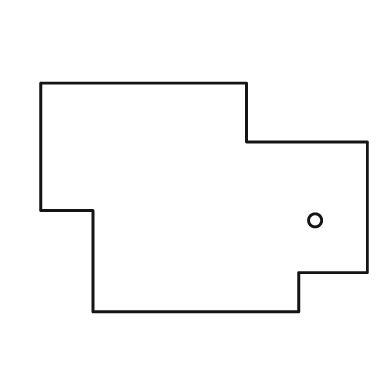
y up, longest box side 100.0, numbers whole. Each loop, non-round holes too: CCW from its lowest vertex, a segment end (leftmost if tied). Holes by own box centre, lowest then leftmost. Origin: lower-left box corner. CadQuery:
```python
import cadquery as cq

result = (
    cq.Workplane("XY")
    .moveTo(16.0, 0.0)
    .lineTo(79.0, 0.0)
    .lineTo(79.0, 12.0)
    .lineTo(100.0, 12.0)
    .lineTo(100.0, 52.0)
    .lineTo(63.0, 52.0)
    .lineTo(63.0, 70.0)
    .lineTo(0.0, 70.0)
    .lineTo(0.0, 31.0)
    .lineTo(16.0, 31.0)
    .close()
    .moveTo(84.0, 28.0)
    .circle(2.0)
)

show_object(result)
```